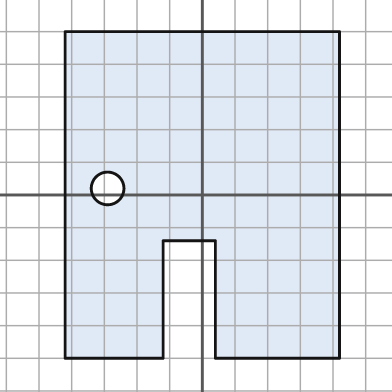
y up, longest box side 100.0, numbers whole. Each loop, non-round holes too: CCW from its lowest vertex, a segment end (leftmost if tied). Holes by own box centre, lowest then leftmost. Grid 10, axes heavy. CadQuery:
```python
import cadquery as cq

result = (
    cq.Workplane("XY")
    .moveTo(-42.0, -50.0)
    .lineTo(-12.0, -50.0)
    .lineTo(-12.0, -14.0)
    .lineTo(4.0, -14.0)
    .lineTo(4.0, -50.0)
    .lineTo(42.0, -50.0)
    .lineTo(42.0, 50.0)
    .lineTo(-42.0, 50.0)
    .close()
    .moveTo(-29.0, 2.0)
    .circle(5.0)
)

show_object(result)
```